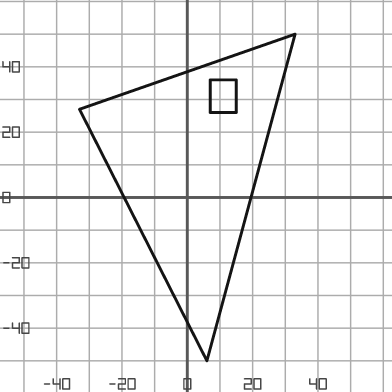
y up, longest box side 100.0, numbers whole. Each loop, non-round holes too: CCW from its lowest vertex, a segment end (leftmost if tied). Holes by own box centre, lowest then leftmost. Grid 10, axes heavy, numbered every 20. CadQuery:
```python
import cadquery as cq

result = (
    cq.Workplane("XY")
    .moveTo(6.0, -50.0)
    .lineTo(33.0, 50.0)
    .lineTo(-33.0, 27.0)
    .close()
    .moveTo(7.0, 26.0)
    .lineTo(15.0, 26.0)
    .lineTo(15.0, 36.0)
    .lineTo(7.0, 36.0)
    .close()
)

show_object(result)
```